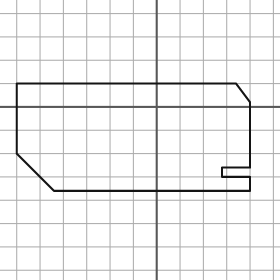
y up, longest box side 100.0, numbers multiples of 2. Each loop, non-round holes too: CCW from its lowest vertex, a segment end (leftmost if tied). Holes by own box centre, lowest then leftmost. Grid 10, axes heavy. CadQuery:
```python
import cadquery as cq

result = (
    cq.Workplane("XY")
    .moveTo(-44.0, -36.0)
    .lineTo(40.0, -36.0)
    .lineTo(40.0, -30.0)
    .lineTo(28.0, -30.0)
    .lineTo(28.0, -26.0)
    .lineTo(40.0, -26.0)
    .lineTo(40.0, 2.0)
    .lineTo(34.0, 10.0)
    .lineTo(-60.0, 10.0)
    .lineTo(-60.0, -20.0)
    .close()
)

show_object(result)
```